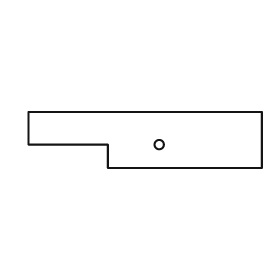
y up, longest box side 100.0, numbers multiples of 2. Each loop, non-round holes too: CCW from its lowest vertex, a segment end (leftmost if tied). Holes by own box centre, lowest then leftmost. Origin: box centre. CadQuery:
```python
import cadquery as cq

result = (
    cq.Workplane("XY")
    .moveTo(-16.0, -12.0)
    .lineTo(50.0, -12.0)
    .lineTo(50.0, 12.0)
    .lineTo(-50.0, 12.0)
    .lineTo(-50.0, -2.0)
    .lineTo(-16.0, -2.0)
    .close()
    .moveTo(6.0, -2.0)
    .circle(2.0)
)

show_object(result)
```